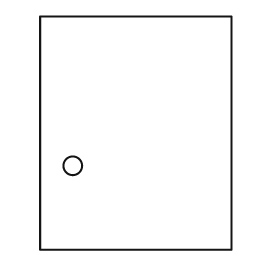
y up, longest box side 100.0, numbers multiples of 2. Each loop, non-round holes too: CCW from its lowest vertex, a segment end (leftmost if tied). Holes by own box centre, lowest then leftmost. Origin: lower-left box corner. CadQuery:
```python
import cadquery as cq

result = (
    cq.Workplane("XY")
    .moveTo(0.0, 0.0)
    .lineTo(82.0, 0.0)
    .lineTo(82.0, 100.0)
    .lineTo(0.0, 100.0)
    .close()
    .moveTo(14.0, 36.0)
    .circle(4.0)
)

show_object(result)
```